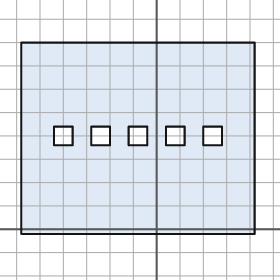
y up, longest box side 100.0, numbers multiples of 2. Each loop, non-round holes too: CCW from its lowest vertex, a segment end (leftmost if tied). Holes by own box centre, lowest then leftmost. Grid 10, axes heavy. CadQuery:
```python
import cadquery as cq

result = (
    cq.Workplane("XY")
    .moveTo(-58.0, -2.0)
    .lineTo(42.0, -2.0)
    .lineTo(42.0, 80.0)
    .lineTo(-58.0, 80.0)
    .close()
    .moveTo(-44.0, 36.0)
    .lineTo(-36.0, 36.0)
    .lineTo(-36.0, 44.0)
    .lineTo(-44.0, 44.0)
    .close()
    .moveTo(-28.0, 36.0)
    .lineTo(-20.0, 36.0)
    .lineTo(-20.0, 44.0)
    .lineTo(-28.0, 44.0)
    .close()
    .moveTo(-12.0, 36.0)
    .lineTo(-4.0, 36.0)
    .lineTo(-4.0, 44.0)
    .lineTo(-12.0, 44.0)
    .close()
    .moveTo(4.0, 36.0)
    .lineTo(12.0, 36.0)
    .lineTo(12.0, 44.0)
    .lineTo(4.0, 44.0)
    .close()
    .moveTo(20.0, 36.0)
    .lineTo(28.0, 36.0)
    .lineTo(28.0, 44.0)
    .lineTo(20.0, 44.0)
    .close()
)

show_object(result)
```